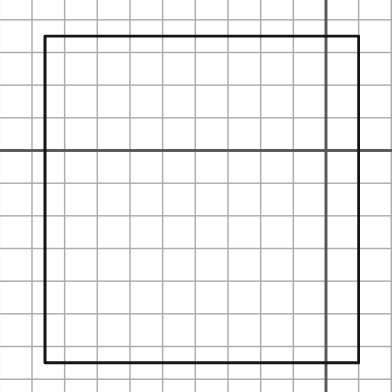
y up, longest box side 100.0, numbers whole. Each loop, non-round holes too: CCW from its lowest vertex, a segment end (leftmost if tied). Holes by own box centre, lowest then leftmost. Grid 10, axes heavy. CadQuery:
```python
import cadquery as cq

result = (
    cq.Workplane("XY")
    .moveTo(-86.0, -65.0)
    .lineTo(10.0, -65.0)
    .lineTo(10.0, 35.0)
    .lineTo(-86.0, 35.0)
    .close()
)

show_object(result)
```